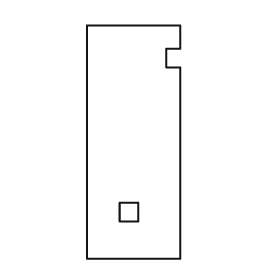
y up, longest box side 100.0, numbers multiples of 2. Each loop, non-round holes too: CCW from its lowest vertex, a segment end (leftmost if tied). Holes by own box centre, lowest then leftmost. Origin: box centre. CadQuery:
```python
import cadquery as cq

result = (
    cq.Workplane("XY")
    .moveTo(-20.0, -50.0)
    .lineTo(20.0, -50.0)
    .lineTo(20.0, 32.0)
    .lineTo(14.0, 32.0)
    .lineTo(14.0, 40.0)
    .lineTo(20.0, 40.0)
    .lineTo(20.0, 50.0)
    .lineTo(-20.0, 50.0)
    .close()
    .moveTo(-6.0, -34.0)
    .lineTo(2.0, -34.0)
    .lineTo(2.0, -26.0)
    .lineTo(-6.0, -26.0)
    .close()
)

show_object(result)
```